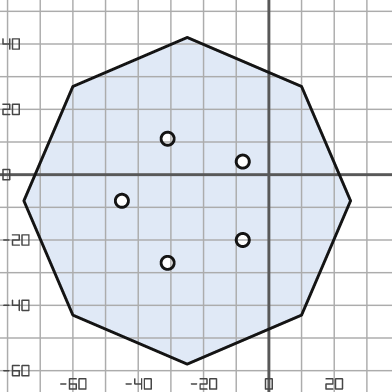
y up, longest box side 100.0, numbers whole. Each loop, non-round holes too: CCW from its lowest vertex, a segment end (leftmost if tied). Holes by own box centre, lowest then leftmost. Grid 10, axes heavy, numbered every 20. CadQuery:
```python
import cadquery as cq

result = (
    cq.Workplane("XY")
    .moveTo(-25.0, -58.0)
    .lineTo(10.0, -43.0)
    .lineTo(25.0, -8.0)
    .lineTo(10.0, 27.0)
    .lineTo(-25.0, 42.0)
    .lineTo(-60.0, 27.0)
    .lineTo(-75.0, -8.0)
    .lineTo(-60.0, -43.0)
    .close()
    .moveTo(-31.0, -27.0)
    .circle(2.0)
    .moveTo(-8.0, -20.0)
    .circle(2.0)
    .moveTo(-45.0, -8.0)
    .circle(2.0)
    .moveTo(-8.0, 4.0)
    .circle(2.0)
    .moveTo(-31.0, 11.0)
    .circle(2.0)
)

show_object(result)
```